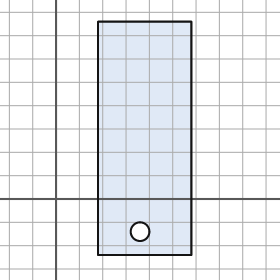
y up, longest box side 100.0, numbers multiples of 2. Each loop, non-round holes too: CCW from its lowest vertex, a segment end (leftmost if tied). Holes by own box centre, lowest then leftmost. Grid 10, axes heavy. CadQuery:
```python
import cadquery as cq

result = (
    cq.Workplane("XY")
    .moveTo(18.0, -24.0)
    .lineTo(58.0, -24.0)
    .lineTo(58.0, 76.0)
    .lineTo(18.0, 76.0)
    .close()
    .moveTo(36.0, -14.0)
    .circle(4.0)
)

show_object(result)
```